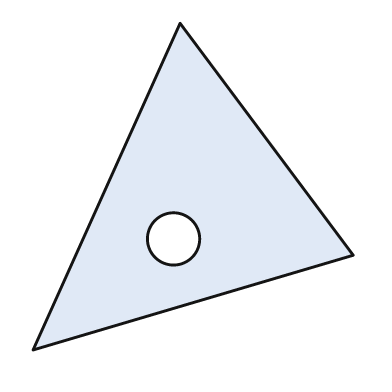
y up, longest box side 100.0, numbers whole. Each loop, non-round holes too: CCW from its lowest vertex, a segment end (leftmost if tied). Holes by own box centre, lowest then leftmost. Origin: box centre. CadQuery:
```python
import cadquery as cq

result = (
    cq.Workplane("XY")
    .moveTo(-49.0, -50.0)
    .lineTo(49.0, -21.0)
    .lineTo(-4.0, 50.0)
    .close()
    .moveTo(-6.0, -16.0)
    .circle(8.0)
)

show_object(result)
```